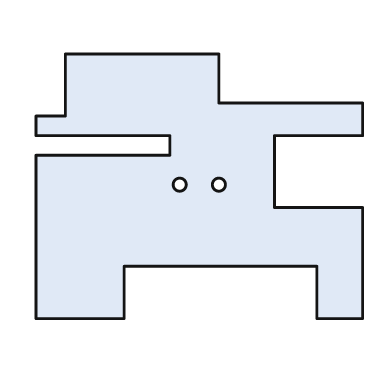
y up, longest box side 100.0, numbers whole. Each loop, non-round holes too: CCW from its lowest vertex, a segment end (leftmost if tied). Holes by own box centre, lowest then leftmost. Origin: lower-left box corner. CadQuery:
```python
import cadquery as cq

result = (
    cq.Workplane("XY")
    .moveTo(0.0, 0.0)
    .lineTo(27.0, 0.0)
    .lineTo(27.0, 16.0)
    .lineTo(86.0, 16.0)
    .lineTo(86.0, 0.0)
    .lineTo(100.0, 0.0)
    .lineTo(100.0, 34.0)
    .lineTo(73.0, 34.0)
    .lineTo(73.0, 56.0)
    .lineTo(100.0, 56.0)
    .lineTo(100.0, 66.0)
    .lineTo(56.0, 66.0)
    .lineTo(56.0, 81.0)
    .lineTo(9.0, 81.0)
    .lineTo(9.0, 62.0)
    .lineTo(0.0, 62.0)
    .lineTo(0.0, 56.0)
    .lineTo(41.0, 56.0)
    .lineTo(41.0, 50.0)
    .lineTo(0.0, 50.0)
    .close()
    .moveTo(44.0, 41.0)
    .circle(2.0)
    .moveTo(56.0, 41.0)
    .circle(2.0)
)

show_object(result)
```